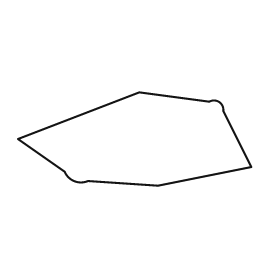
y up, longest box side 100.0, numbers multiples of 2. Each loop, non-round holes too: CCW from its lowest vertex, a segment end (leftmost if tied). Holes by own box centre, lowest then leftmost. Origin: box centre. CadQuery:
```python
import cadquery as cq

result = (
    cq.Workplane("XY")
    .moveTo(10.0, -20.0)
    .lineTo(50.0, -12.0)
    .lineTo(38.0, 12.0)
    .threePointArc((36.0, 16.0), (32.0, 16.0))
    .lineTo(2.0, 20.0)
    .lineTo(-50.0, 0.0)
    .lineTo(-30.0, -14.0)
    .threePointArc((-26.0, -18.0), (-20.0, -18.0))
    .close()
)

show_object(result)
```